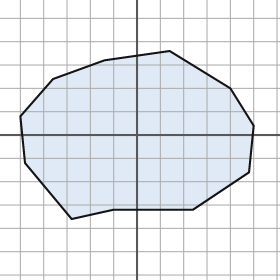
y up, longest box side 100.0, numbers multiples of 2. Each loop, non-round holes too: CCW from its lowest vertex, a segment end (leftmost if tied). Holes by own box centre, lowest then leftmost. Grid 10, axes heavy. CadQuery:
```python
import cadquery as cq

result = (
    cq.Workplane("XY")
    .moveTo(-28.0, -36.0)
    .lineTo(-10.0, -32.0)
    .lineTo(24.0, -32.0)
    .lineTo(48.0, -16.0)
    .lineTo(50.0, 4.0)
    .lineTo(40.0, 20.0)
    .lineTo(14.0, 36.0)
    .lineTo(-14.0, 32.0)
    .lineTo(-36.0, 24.0)
    .lineTo(-50.0, 8.0)
    .lineTo(-48.0, -12.0)
    .close()
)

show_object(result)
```